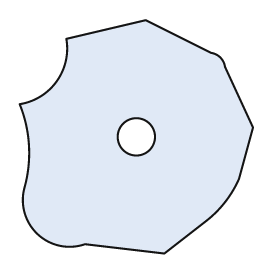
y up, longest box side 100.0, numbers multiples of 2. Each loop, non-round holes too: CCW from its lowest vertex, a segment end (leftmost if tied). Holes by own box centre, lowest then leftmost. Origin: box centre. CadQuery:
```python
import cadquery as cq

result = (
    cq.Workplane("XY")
    .moveTo(12.0, -50.0)
    .lineTo(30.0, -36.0)
    .threePointArc((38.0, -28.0), (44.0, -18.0))
    .lineTo(50.0, 4.0)
    .lineTo(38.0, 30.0)
    .threePointArc((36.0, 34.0), (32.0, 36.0))
    .lineTo(4.0, 50.0)
    .lineTo(-30.0, 42.0)
    .threePointArc((-34.0, 24.0), (-50.0, 14.0))
    .threePointArc((-46.0, -4.0), (-48.0, -22.0))
    .threePointArc((-42.0, -42.0), (-22.0, -46.0))
    .close()
    .moveTo(0.0, 0.0)
    .circle(8.0)
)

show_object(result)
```